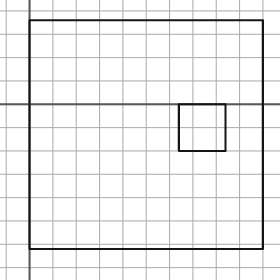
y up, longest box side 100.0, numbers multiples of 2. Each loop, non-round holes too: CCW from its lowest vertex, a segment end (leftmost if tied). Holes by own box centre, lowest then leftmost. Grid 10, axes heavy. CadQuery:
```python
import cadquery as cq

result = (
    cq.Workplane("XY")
    .moveTo(0.0, -62.0)
    .lineTo(100.0, -62.0)
    .lineTo(100.0, 36.0)
    .lineTo(0.0, 36.0)
    .close()
    .moveTo(64.0, -20.0)
    .lineTo(84.0, -20.0)
    .lineTo(84.0, 0.0)
    .lineTo(64.0, 0.0)
    .close()
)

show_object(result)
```